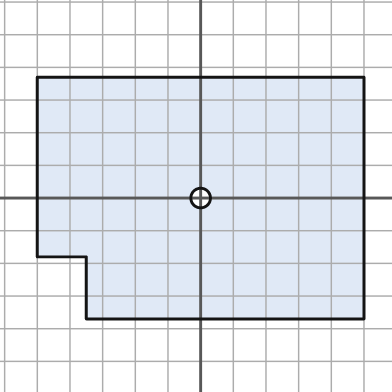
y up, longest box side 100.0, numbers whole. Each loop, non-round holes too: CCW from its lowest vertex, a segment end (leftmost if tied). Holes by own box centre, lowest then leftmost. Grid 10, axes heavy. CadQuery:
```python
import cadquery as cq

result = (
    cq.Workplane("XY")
    .moveTo(-35.0, -37.0)
    .lineTo(50.0, -37.0)
    .lineTo(50.0, 37.0)
    .lineTo(-50.0, 37.0)
    .lineTo(-50.0, -18.0)
    .lineTo(-35.0, -18.0)
    .close()
    .moveTo(0.0, 0.0)
    .circle(3.0)
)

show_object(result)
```